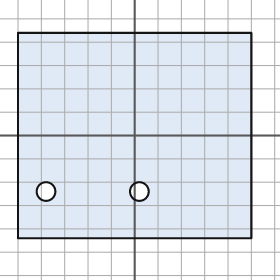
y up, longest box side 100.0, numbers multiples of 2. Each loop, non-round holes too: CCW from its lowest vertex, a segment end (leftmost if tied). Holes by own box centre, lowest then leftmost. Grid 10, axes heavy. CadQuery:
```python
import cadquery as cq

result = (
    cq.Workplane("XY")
    .moveTo(-50.0, -44.0)
    .lineTo(50.0, -44.0)
    .lineTo(50.0, 44.0)
    .lineTo(-50.0, 44.0)
    .close()
    .moveTo(-38.0, -24.0)
    .circle(4.0)
    .moveTo(2.0, -24.0)
    .circle(4.0)
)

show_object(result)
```